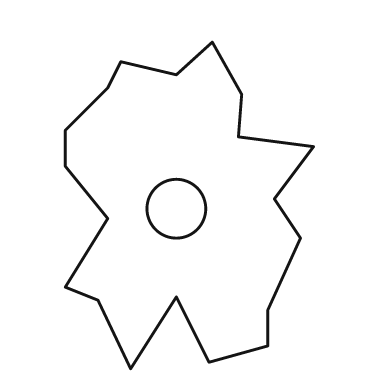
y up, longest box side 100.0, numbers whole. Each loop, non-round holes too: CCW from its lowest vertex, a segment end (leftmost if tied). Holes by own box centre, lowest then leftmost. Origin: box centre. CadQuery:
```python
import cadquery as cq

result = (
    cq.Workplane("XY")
    .moveTo(-18.0, -50.0)
    .lineTo(-4.0, -28.0)
    .lineTo(6.0, -48.0)
    .lineTo(24.0, -43.0)
    .lineTo(24.0, -32.0)
    .lineTo(34.0, -10.0)
    .lineTo(26.0, 2.0)
    .lineTo(38.0, 18.0)
    .lineTo(15.0, 21.0)
    .lineTo(16.0, 34.0)
    .lineTo(7.0, 50.0)
    .lineTo(-4.0, 40.0)
    .lineTo(-21.0, 44.0)
    .lineTo(-25.0, 36.0)
    .lineTo(-38.0, 23.0)
    .lineTo(-38.0, 12.0)
    .lineTo(-25.0, -4.0)
    .lineTo(-38.0, -25.0)
    .lineTo(-28.0, -29.0)
    .close()
    .moveTo(-4.0, -1.0)
    .circle(9.0)
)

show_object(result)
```